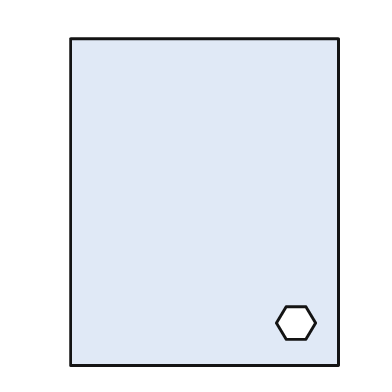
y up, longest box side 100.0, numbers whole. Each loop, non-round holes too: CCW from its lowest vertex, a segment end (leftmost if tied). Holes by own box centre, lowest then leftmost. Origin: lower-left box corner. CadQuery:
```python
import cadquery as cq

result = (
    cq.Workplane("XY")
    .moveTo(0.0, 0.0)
    .lineTo(82.0, 0.0)
    .lineTo(82.0, 100.0)
    .lineTo(0.0, 100.0)
    .close()
    .moveTo(66.0, 8.0)
    .lineTo(72.0, 8.0)
    .lineTo(75.0, 13.0)
    .lineTo(72.0, 18.0)
    .lineTo(66.0, 18.0)
    .lineTo(63.0, 13.0)
    .close()
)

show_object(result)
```